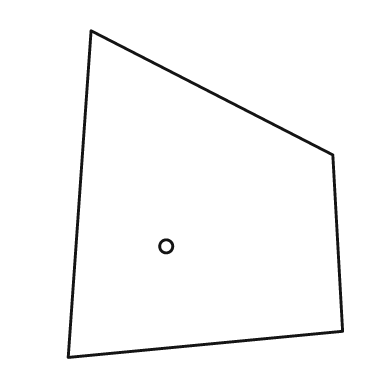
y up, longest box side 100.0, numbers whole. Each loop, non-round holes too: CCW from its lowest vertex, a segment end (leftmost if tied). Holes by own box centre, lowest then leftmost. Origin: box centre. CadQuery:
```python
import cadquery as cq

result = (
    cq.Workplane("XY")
    .moveTo(-42.0, -50.0)
    .lineTo(42.0, -42.0)
    .lineTo(39.0, 12.0)
    .lineTo(-35.0, 50.0)
    .close()
    .moveTo(-12.0, -16.0)
    .circle(2.0)
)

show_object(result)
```